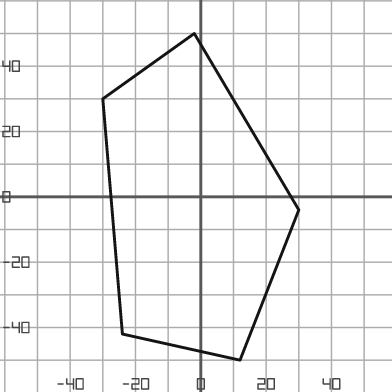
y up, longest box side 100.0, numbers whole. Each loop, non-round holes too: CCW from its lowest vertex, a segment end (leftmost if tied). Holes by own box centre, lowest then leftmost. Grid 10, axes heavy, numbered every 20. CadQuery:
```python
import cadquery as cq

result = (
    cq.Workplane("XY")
    .moveTo(12.0, -50.0)
    .lineTo(30.0, -4.0)
    .lineTo(-2.0, 50.0)
    .lineTo(-30.0, 30.0)
    .lineTo(-24.0, -42.0)
    .close()
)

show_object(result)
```